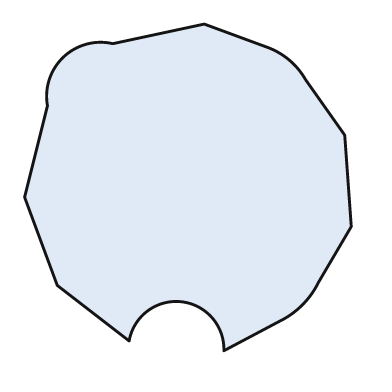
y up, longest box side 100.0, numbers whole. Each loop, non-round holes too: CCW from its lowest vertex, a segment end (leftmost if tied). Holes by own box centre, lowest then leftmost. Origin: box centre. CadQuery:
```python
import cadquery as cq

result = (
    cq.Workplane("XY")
    .moveTo(11.0, -50.0)
    .lineTo(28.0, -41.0)
    .threePointArc((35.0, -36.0), (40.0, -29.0))
    .lineTo(50.0, -12.0)
    .lineTo(48.0, 16.0)
    .lineTo(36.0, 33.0)
    .threePointArc((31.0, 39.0), (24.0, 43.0))
    .lineTo(5.0, 50.0)
    .lineTo(-23.0, 44.0)
    .threePointArc((-38.0, 40.0), (-43.0, 25.0))
    .lineTo(-50.0, -3.0)
    .lineTo(-40.0, -30.0)
    .lineTo(-18.0, -47.0)
    .threePointArc((-2.0, -35.0), (11.0, -50.0))
    .close()
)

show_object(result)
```